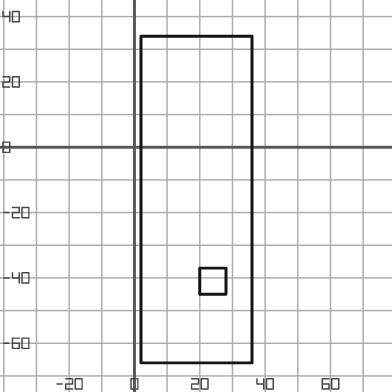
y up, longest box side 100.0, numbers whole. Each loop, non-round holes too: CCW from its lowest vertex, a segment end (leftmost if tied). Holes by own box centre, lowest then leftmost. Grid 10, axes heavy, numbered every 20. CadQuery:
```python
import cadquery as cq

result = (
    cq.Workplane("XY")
    .moveTo(2.0, -66.0)
    .lineTo(36.0, -66.0)
    .lineTo(36.0, 34.0)
    .lineTo(2.0, 34.0)
    .close()
    .moveTo(20.0, -45.0)
    .lineTo(28.0, -45.0)
    .lineTo(28.0, -37.0)
    .lineTo(20.0, -37.0)
    .close()
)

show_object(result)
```